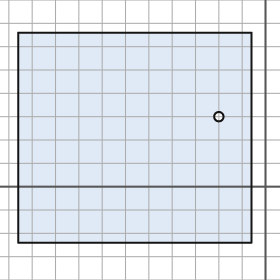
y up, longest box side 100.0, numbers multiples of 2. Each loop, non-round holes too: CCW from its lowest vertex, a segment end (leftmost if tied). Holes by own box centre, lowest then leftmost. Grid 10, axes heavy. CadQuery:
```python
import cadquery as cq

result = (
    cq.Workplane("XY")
    .moveTo(-106.0, -24.0)
    .lineTo(-6.0, -24.0)
    .lineTo(-6.0, 66.0)
    .lineTo(-106.0, 66.0)
    .close()
    .moveTo(-20.0, 30.0)
    .circle(2.0)
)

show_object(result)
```